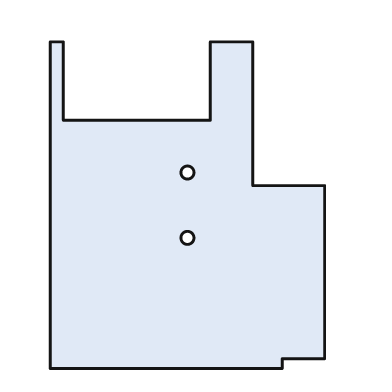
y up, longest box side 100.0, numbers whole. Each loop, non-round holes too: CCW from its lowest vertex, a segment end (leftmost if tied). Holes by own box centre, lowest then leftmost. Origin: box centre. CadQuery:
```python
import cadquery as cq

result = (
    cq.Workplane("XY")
    .moveTo(-42.0, -50.0)
    .lineTo(29.0, -50.0)
    .lineTo(29.0, -47.0)
    .lineTo(42.0, -47.0)
    .lineTo(42.0, 6.0)
    .lineTo(20.0, 6.0)
    .lineTo(20.0, 50.0)
    .lineTo(7.0, 50.0)
    .lineTo(7.0, 26.0)
    .lineTo(-38.0, 26.0)
    .lineTo(-38.0, 50.0)
    .lineTo(-42.0, 50.0)
    .close()
    .moveTo(0.0, -10.0)
    .circle(2.0)
    .moveTo(0.0, 10.0)
    .circle(2.0)
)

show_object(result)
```